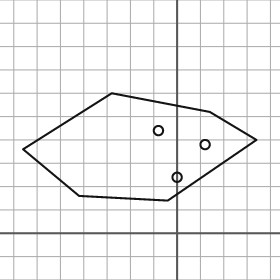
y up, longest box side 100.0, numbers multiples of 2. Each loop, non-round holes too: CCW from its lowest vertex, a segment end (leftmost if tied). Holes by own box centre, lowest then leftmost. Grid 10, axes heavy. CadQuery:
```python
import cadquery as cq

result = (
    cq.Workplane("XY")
    .moveTo(-4.0, 14.0)
    .lineTo(34.0, 40.0)
    .lineTo(14.0, 52.0)
    .lineTo(-28.0, 60.0)
    .lineTo(-66.0, 36.0)
    .lineTo(-42.0, 16.0)
    .close()
    .moveTo(0.0, 24.0)
    .circle(2.0)
    .moveTo(12.0, 38.0)
    .circle(2.0)
    .moveTo(-8.0, 44.0)
    .circle(2.0)
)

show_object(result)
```